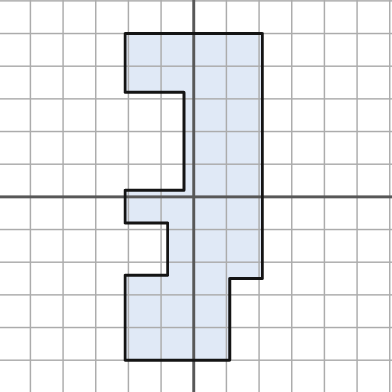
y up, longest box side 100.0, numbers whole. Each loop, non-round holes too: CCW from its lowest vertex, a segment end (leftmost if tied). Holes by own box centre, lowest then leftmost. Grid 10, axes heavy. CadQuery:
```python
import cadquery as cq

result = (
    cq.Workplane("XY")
    .moveTo(-21.0, -50.0)
    .lineTo(11.0, -50.0)
    .lineTo(11.0, -25.0)
    .lineTo(21.0, -25.0)
    .lineTo(21.0, 50.0)
    .lineTo(-21.0, 50.0)
    .lineTo(-21.0, 32.0)
    .lineTo(-3.0, 32.0)
    .lineTo(-3.0, 2.0)
    .lineTo(-21.0, 2.0)
    .lineTo(-21.0, -8.0)
    .lineTo(-8.0, -8.0)
    .lineTo(-8.0, -24.0)
    .lineTo(-21.0, -24.0)
    .close()
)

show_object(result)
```